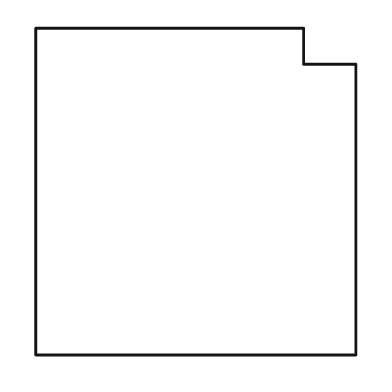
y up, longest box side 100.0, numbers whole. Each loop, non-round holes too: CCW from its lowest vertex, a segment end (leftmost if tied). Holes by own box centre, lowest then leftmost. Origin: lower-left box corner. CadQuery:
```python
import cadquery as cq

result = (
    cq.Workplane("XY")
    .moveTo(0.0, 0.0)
    .lineTo(98.0, 0.0)
    .lineTo(98.0, 89.0)
    .lineTo(82.0, 89.0)
    .lineTo(82.0, 100.0)
    .lineTo(0.0, 100.0)
    .close()
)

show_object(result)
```